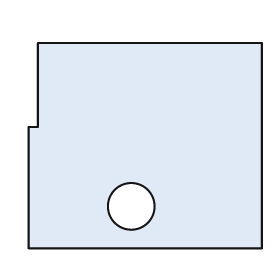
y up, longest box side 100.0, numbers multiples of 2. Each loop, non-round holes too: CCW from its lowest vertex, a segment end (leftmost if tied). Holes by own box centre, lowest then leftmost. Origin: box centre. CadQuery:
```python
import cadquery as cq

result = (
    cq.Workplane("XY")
    .moveTo(-50.0, -44.0)
    .lineTo(50.0, -44.0)
    .lineTo(50.0, 44.0)
    .lineTo(-46.0, 44.0)
    .lineTo(-46.0, 8.0)
    .lineTo(-50.0, 8.0)
    .close()
    .moveTo(-6.0, -26.0)
    .circle(10.0)
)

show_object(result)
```